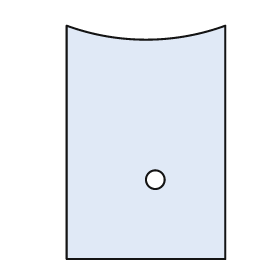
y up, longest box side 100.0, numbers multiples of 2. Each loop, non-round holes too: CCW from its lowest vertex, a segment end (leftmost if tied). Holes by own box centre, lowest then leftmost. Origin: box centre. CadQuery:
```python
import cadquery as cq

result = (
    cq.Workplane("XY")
    .moveTo(-34.0, -50.0)
    .lineTo(34.0, -50.0)
    .lineTo(34.0, 50.0)
    .threePointArc((0.0, 44.0), (-34.0, 50.0))
    .close()
    .moveTo(4.0, -16.0)
    .circle(4.0)
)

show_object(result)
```